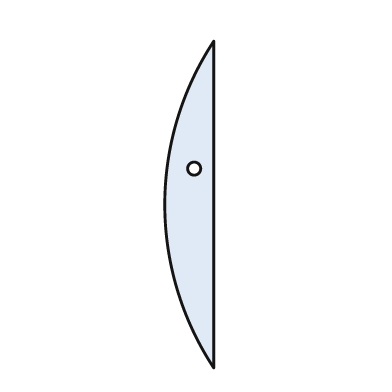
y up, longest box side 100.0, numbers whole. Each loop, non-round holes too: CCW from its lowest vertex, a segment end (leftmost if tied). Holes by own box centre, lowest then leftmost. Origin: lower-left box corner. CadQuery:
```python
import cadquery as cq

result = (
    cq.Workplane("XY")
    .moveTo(15.0, 0.0)
    .lineTo(15.0, 100.0)
    .threePointArc((0.0, 50.0), (15.0, 0.0))
    .close()
    .moveTo(9.0, 61.0)
    .circle(2.0)
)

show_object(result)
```